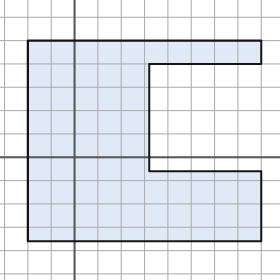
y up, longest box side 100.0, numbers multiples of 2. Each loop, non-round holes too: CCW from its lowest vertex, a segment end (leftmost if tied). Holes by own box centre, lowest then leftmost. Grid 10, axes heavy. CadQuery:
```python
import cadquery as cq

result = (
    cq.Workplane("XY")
    .moveTo(-20.0, -36.0)
    .lineTo(80.0, -36.0)
    .lineTo(80.0, -6.0)
    .lineTo(32.0, -6.0)
    .lineTo(32.0, 40.0)
    .lineTo(80.0, 40.0)
    .lineTo(80.0, 50.0)
    .lineTo(-20.0, 50.0)
    .close()
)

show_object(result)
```